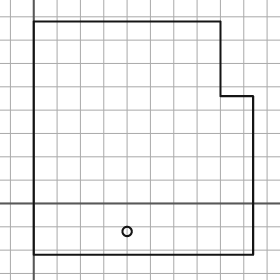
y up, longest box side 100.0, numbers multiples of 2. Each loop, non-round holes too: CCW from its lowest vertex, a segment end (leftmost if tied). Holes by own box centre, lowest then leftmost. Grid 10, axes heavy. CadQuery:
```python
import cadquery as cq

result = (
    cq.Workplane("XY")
    .moveTo(0.0, -22.0)
    .lineTo(94.0, -22.0)
    .lineTo(94.0, 46.0)
    .lineTo(80.0, 46.0)
    .lineTo(80.0, 78.0)
    .lineTo(0.0, 78.0)
    .close()
    .moveTo(40.0, -12.0)
    .circle(2.0)
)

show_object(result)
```